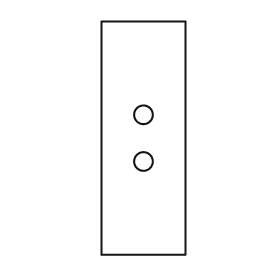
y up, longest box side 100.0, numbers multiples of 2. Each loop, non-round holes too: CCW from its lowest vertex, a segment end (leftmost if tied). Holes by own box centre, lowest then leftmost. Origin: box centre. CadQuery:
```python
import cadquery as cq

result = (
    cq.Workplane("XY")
    .moveTo(-18.0, -50.0)
    .lineTo(18.0, -50.0)
    .lineTo(18.0, 50.0)
    .lineTo(-18.0, 50.0)
    .close()
    .moveTo(0.0, -10.0)
    .circle(4.0)
    .moveTo(0.0, 10.0)
    .circle(4.0)
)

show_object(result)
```